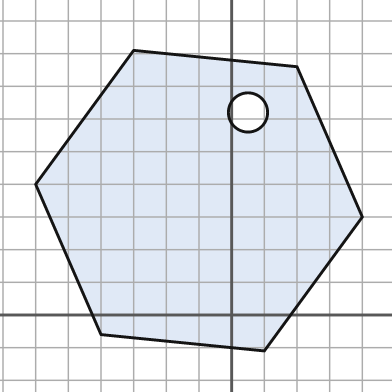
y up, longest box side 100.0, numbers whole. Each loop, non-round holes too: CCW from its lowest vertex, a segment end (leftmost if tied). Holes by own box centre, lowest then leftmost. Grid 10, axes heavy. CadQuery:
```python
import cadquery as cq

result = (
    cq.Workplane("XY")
    .moveTo(10.0, -11.0)
    .lineTo(40.0, 30.0)
    .lineTo(20.0, 76.0)
    .lineTo(-30.0, 81.0)
    .lineTo(-60.0, 40.0)
    .lineTo(-40.0, -6.0)
    .close()
    .moveTo(5.0, 62.0)
    .circle(6.0)
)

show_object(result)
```